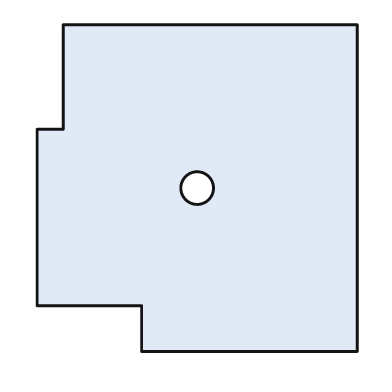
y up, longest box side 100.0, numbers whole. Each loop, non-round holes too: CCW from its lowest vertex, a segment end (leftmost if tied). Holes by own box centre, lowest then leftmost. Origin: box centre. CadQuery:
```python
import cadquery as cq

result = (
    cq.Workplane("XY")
    .moveTo(-17.0, -50.0)
    .lineTo(49.0, -50.0)
    .lineTo(49.0, 50.0)
    .lineTo(-41.0, 50.0)
    .lineTo(-41.0, 18.0)
    .lineTo(-49.0, 18.0)
    .lineTo(-49.0, -36.0)
    .lineTo(-17.0, -36.0)
    .close()
    .moveTo(0.0, 0.0)
    .circle(5.0)
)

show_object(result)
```